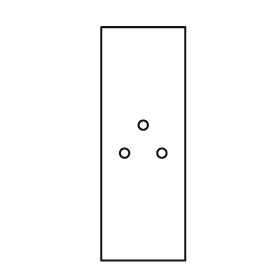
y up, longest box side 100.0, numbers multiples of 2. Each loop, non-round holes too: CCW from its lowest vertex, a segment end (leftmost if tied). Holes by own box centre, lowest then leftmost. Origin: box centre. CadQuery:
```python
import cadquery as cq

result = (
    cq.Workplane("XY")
    .moveTo(-18.0, -50.0)
    .lineTo(18.0, -50.0)
    .lineTo(18.0, 50.0)
    .lineTo(-18.0, 50.0)
    .close()
    .moveTo(-8.0, -4.0)
    .circle(2.0)
    .moveTo(8.0, -4.0)
    .circle(2.0)
    .moveTo(0.0, 8.0)
    .circle(2.0)
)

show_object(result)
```